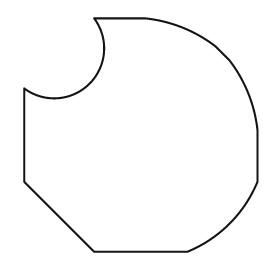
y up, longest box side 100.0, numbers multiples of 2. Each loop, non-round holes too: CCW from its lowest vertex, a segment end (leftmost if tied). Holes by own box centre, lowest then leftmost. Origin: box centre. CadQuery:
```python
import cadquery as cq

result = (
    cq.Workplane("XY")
    .moveTo(-20.0, -50.0)
    .lineTo(20.0, -50.0)
    .threePointArc((38.0, -38.0), (50.0, -20.0))
    .lineTo(50.0, 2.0)
    .threePointArc((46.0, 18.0), (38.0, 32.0))
    .lineTo(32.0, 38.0)
    .threePointArc((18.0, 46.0), (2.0, 50.0))
    .lineTo(-20.0, 50.0)
    .threePointArc((-22.0, 22.0), (-50.0, 20.0))
    .lineTo(-50.0, -20.0)
    .close()
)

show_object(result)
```